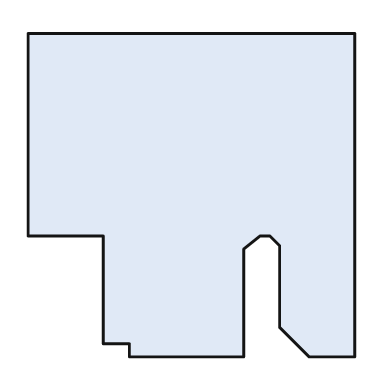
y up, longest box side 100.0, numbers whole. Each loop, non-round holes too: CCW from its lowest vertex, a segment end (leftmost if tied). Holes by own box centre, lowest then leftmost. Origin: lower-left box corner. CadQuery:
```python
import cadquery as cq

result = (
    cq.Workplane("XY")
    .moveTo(31.0, 0.0)
    .lineTo(66.0, 0.0)
    .lineTo(66.0, 33.0)
    .lineTo(71.0, 37.0)
    .lineTo(74.0, 37.0)
    .lineTo(77.0, 34.0)
    .lineTo(77.0, 9.0)
    .lineTo(86.0, 0.0)
    .lineTo(100.0, 0.0)
    .lineTo(100.0, 99.0)
    .lineTo(0.0, 99.0)
    .lineTo(0.0, 37.0)
    .lineTo(23.0, 37.0)
    .lineTo(23.0, 4.0)
    .lineTo(31.0, 4.0)
    .close()
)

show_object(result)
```